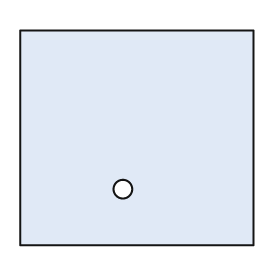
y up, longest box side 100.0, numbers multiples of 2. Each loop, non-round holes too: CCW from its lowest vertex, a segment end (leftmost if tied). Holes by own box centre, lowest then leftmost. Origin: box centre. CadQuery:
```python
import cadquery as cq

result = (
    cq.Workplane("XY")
    .moveTo(-50.0, -46.0)
    .lineTo(50.0, -46.0)
    .lineTo(50.0, 46.0)
    .lineTo(-50.0, 46.0)
    .close()
    .moveTo(-6.0, -22.0)
    .circle(4.0)
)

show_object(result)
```